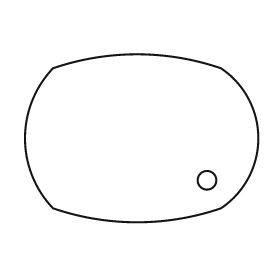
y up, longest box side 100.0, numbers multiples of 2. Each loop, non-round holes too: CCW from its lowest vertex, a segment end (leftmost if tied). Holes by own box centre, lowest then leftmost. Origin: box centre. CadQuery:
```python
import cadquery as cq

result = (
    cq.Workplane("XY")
    .moveTo(-38.0, -30.0)
    .threePointArc((-2.0, -36.0), (34.0, -30.0))
    .threePointArc((50.0, 0.0), (34.0, 30.0))
    .threePointArc((-2.0, 36.0), (-38.0, 30.0))
    .threePointArc((-50.0, 0.0), (-38.0, -30.0))
    .close()
    .moveTo(28.0, -18.0)
    .circle(4.0)
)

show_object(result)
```